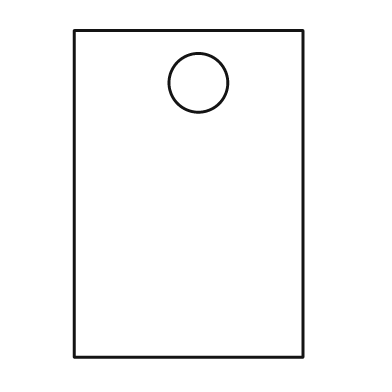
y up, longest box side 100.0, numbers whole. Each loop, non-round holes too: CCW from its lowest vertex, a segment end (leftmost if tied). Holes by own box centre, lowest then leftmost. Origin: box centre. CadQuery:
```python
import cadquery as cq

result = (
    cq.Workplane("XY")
    .moveTo(-35.0, -50.0)
    .lineTo(35.0, -50.0)
    .lineTo(35.0, 50.0)
    .lineTo(-35.0, 50.0)
    .close()
    .moveTo(3.0, 34.0)
    .circle(9.0)
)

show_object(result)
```